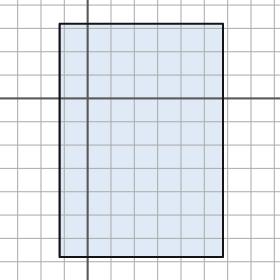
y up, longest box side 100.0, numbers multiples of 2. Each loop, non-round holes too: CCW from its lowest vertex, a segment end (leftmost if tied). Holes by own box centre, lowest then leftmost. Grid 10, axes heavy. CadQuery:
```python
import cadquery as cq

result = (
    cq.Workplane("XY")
    .moveTo(-12.0, -68.0)
    .lineTo(58.0, -68.0)
    .lineTo(58.0, 32.0)
    .lineTo(-12.0, 32.0)
    .close()
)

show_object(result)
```